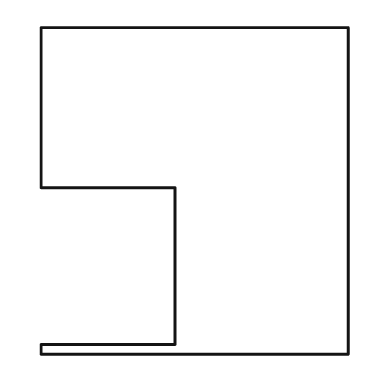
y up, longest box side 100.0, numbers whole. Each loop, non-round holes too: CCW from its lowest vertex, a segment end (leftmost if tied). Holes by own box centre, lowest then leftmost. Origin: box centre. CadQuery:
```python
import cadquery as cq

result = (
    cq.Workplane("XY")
    .moveTo(-47.0, -50.0)
    .lineTo(47.0, -50.0)
    .lineTo(47.0, 50.0)
    .lineTo(-47.0, 50.0)
    .lineTo(-47.0, 1.0)
    .lineTo(-6.0, 1.0)
    .lineTo(-6.0, -47.0)
    .lineTo(-47.0, -47.0)
    .close()
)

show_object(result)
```